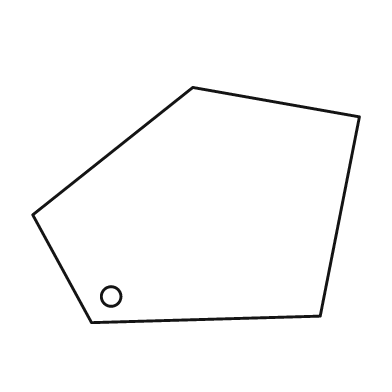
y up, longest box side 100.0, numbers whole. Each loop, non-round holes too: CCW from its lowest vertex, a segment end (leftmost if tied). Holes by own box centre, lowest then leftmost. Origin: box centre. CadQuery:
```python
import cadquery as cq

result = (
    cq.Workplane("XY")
    .moveTo(-32.0, -36.0)
    .lineTo(38.0, -34.0)
    .lineTo(50.0, 27.0)
    .lineTo(-1.0, 36.0)
    .lineTo(-50.0, -3.0)
    .close()
    .moveTo(-26.0, -28.0)
    .circle(3.0)
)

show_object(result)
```